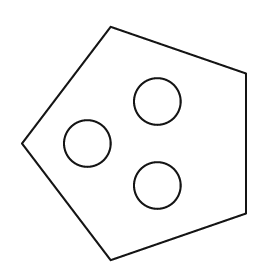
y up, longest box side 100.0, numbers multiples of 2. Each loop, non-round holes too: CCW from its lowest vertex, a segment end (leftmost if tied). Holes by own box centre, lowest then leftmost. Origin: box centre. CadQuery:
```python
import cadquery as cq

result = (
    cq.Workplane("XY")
    .moveTo(-10.0, -50.0)
    .lineTo(48.0, -30.0)
    .lineTo(48.0, 30.0)
    .lineTo(-10.0, 50.0)
    .lineTo(-48.0, 0.0)
    .close()
    .moveTo(10.0, -18.0)
    .circle(10.0)
    .moveTo(-20.0, 0.0)
    .circle(10.0)
    .moveTo(10.0, 18.0)
    .circle(10.0)
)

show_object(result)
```